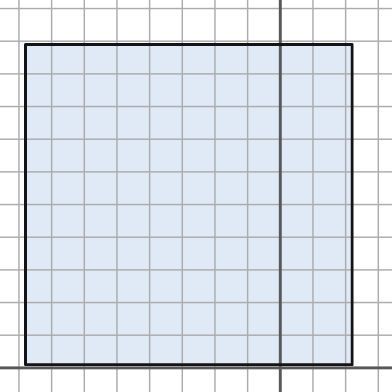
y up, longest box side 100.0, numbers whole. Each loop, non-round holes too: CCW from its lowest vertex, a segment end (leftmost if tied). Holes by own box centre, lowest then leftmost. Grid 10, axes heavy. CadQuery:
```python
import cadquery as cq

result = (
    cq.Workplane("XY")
    .moveTo(-78.0, 1.0)
    .lineTo(22.0, 1.0)
    .lineTo(22.0, 99.0)
    .lineTo(-78.0, 99.0)
    .close()
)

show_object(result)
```